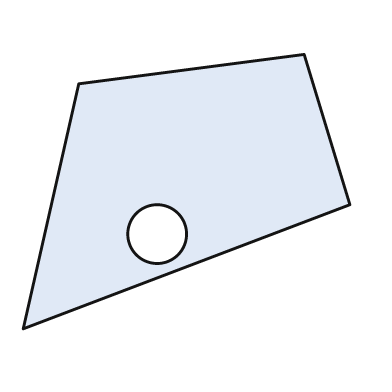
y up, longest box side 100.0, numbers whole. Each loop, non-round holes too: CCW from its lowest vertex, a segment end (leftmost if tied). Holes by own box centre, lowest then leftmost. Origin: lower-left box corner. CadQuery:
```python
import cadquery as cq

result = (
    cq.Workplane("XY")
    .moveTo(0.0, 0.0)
    .lineTo(100.0, 38.0)
    .lineTo(86.0, 84.0)
    .lineTo(17.0, 75.0)
    .close()
    .moveTo(41.0, 29.0)
    .circle(9.0)
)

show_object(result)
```